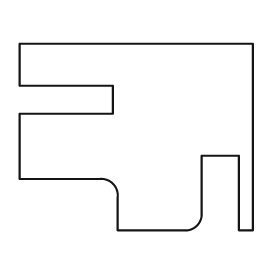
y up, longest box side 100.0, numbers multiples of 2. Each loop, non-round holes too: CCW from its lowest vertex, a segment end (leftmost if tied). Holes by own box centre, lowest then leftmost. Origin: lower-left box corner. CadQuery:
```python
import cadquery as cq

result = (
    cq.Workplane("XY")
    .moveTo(42.0, 0.0)
    .lineTo(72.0, 0.0)
    .threePointArc((76.0, 2.0), (78.0, 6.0))
    .lineTo(78.0, 32.0)
    .lineTo(94.0, 32.0)
    .lineTo(94.0, 0.0)
    .lineTo(100.0, 0.0)
    .lineTo(100.0, 80.0)
    .lineTo(0.0, 80.0)
    .lineTo(0.0, 62.0)
    .lineTo(40.0, 62.0)
    .lineTo(40.0, 50.0)
    .lineTo(0.0, 50.0)
    .lineTo(0.0, 22.0)
    .lineTo(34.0, 22.0)
    .threePointArc((40.0, 20.0), (42.0, 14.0))
    .close()
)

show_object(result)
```